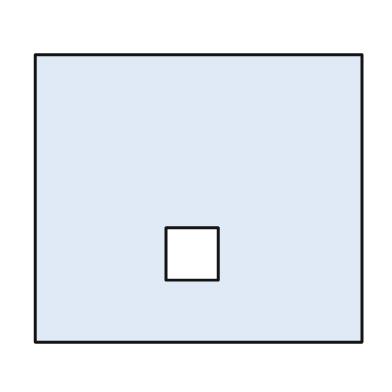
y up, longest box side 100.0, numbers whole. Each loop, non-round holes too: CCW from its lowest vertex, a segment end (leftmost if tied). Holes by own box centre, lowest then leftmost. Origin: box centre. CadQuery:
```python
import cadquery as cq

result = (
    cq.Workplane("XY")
    .moveTo(-50.0, -44.0)
    .lineTo(50.0, -44.0)
    .lineTo(50.0, 44.0)
    .lineTo(-50.0, 44.0)
    .close()
    .moveTo(-10.0, -25.0)
    .lineTo(6.0, -25.0)
    .lineTo(6.0, -9.0)
    .lineTo(-10.0, -9.0)
    .close()
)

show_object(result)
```